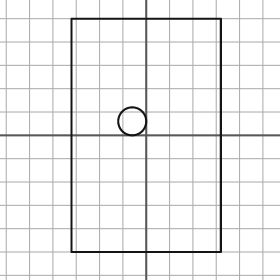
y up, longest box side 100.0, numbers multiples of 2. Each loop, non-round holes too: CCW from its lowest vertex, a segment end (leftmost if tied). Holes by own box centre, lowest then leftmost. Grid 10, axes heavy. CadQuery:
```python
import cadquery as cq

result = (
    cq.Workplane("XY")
    .moveTo(-32.0, -50.0)
    .lineTo(32.0, -50.0)
    .lineTo(32.0, 50.0)
    .lineTo(-32.0, 50.0)
    .close()
    .moveTo(-6.0, 6.0)
    .circle(6.0)
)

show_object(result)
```